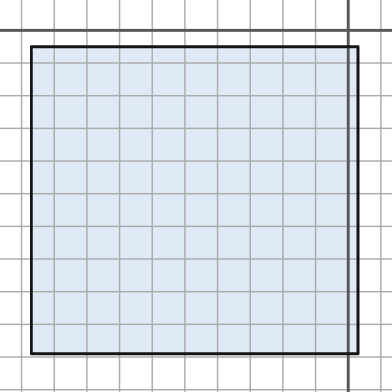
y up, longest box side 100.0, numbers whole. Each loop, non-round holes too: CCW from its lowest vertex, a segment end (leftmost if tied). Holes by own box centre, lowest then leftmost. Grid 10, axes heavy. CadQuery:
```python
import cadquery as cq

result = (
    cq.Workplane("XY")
    .moveTo(-97.0, -99.0)
    .lineTo(3.0, -99.0)
    .lineTo(3.0, -5.0)
    .lineTo(-97.0, -5.0)
    .close()
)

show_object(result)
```